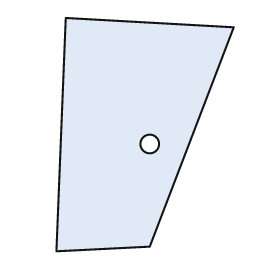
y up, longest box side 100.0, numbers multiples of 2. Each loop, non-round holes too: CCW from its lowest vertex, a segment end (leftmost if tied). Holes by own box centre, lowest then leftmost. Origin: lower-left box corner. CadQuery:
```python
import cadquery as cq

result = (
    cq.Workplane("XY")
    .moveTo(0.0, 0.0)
    .lineTo(40.0, 2.0)
    .lineTo(76.0, 96.0)
    .lineTo(4.0, 100.0)
    .close()
    .moveTo(40.0, 46.0)
    .circle(4.0)
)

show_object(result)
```